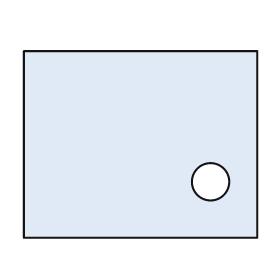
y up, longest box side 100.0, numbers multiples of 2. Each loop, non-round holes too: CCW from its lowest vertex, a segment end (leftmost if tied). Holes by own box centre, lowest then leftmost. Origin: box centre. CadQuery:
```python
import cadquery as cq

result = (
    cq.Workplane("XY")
    .moveTo(-50.0, -40.0)
    .lineTo(50.0, -40.0)
    .lineTo(50.0, 40.0)
    .lineTo(-50.0, 40.0)
    .close()
    .moveTo(30.0, -16.0)
    .circle(8.0)
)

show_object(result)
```